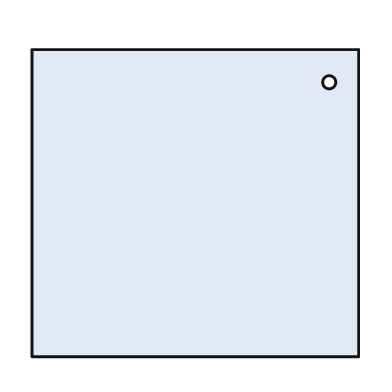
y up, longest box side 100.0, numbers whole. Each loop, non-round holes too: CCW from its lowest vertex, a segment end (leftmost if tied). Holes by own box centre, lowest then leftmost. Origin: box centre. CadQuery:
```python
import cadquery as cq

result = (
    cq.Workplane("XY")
    .moveTo(-50.0, -47.0)
    .lineTo(50.0, -47.0)
    .lineTo(50.0, 47.0)
    .lineTo(-50.0, 47.0)
    .close()
    .moveTo(41.0, 37.0)
    .circle(2.0)
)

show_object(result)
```